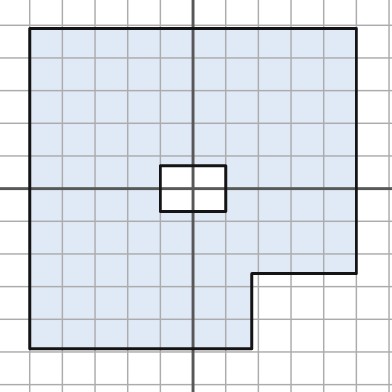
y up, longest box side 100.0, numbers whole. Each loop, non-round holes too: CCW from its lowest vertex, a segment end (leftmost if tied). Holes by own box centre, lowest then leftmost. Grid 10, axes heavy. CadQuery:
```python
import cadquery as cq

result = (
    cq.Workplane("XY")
    .moveTo(-50.0, -49.0)
    .lineTo(18.0, -49.0)
    .lineTo(18.0, -26.0)
    .lineTo(50.0, -26.0)
    .lineTo(50.0, 49.0)
    .lineTo(-50.0, 49.0)
    .close()
    .moveTo(-10.0, -7.0)
    .lineTo(10.0, -7.0)
    .lineTo(10.0, 7.0)
    .lineTo(-10.0, 7.0)
    .close()
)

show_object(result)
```